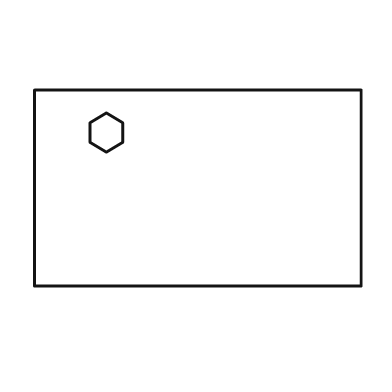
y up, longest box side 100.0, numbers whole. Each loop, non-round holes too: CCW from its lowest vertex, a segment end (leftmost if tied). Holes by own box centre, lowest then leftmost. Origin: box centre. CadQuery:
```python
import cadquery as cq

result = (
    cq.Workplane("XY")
    .moveTo(-50.0, -30.0)
    .lineTo(50.0, -30.0)
    .lineTo(50.0, 30.0)
    .lineTo(-50.0, 30.0)
    .close()
    .moveTo(-28.0, 11.0)
    .lineTo(-23.0, 14.0)
    .lineTo(-23.0, 20.0)
    .lineTo(-28.0, 23.0)
    .lineTo(-33.0, 20.0)
    .lineTo(-33.0, 14.0)
    .close()
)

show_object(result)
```